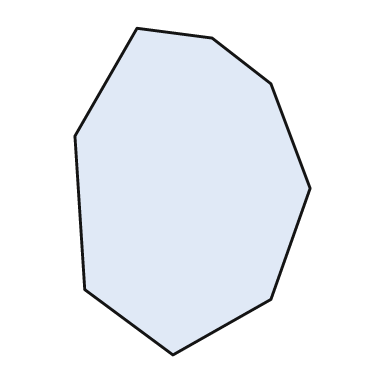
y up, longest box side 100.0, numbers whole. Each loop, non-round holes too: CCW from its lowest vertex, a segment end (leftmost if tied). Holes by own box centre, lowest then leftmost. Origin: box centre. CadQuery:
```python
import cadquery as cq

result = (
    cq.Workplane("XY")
    .moveTo(-6.0, -50.0)
    .lineTo(24.0, -33.0)
    .lineTo(36.0, 1.0)
    .lineTo(24.0, 33.0)
    .lineTo(6.0, 47.0)
    .lineTo(-17.0, 50.0)
    .lineTo(-36.0, 17.0)
    .lineTo(-33.0, -30.0)
    .close()
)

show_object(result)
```